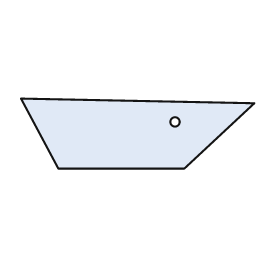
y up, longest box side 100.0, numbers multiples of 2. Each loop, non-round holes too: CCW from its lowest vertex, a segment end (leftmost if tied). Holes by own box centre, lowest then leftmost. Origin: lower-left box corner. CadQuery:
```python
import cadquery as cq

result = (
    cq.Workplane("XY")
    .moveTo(16.0, 0.0)
    .lineTo(70.0, 0.0)
    .lineTo(100.0, 28.0)
    .lineTo(0.0, 30.0)
    .close()
    .moveTo(66.0, 20.0)
    .circle(2.0)
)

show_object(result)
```